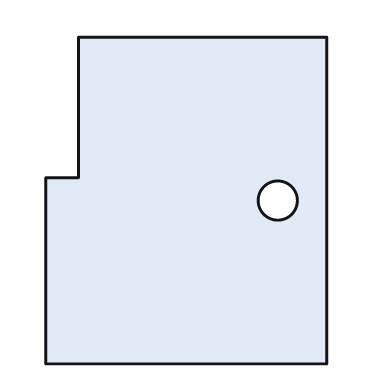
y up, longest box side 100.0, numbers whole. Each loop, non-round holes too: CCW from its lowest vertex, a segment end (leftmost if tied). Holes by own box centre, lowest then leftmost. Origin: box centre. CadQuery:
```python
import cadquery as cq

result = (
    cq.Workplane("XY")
    .moveTo(-43.0, -50.0)
    .lineTo(43.0, -50.0)
    .lineTo(43.0, 50.0)
    .lineTo(-33.0, 50.0)
    .lineTo(-33.0, 7.0)
    .lineTo(-43.0, 7.0)
    .close()
    .moveTo(28.0, 0.0)
    .circle(6.0)
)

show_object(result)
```